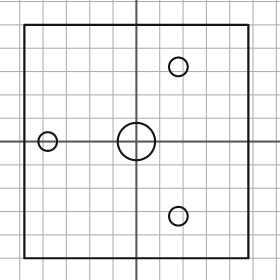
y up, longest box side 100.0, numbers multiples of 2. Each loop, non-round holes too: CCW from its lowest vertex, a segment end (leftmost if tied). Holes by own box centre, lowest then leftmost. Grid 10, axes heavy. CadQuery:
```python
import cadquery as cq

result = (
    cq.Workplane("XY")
    .moveTo(-48.0, -50.0)
    .lineTo(48.0, -50.0)
    .lineTo(48.0, 50.0)
    .lineTo(-48.0, 50.0)
    .close()
    .moveTo(18.0, -32.0)
    .circle(4.0)
    .moveTo(-38.0, 0.0)
    .circle(4.0)
    .moveTo(0.0, 0.0)
    .circle(8.0)
    .moveTo(18.0, 32.0)
    .circle(4.0)
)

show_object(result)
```